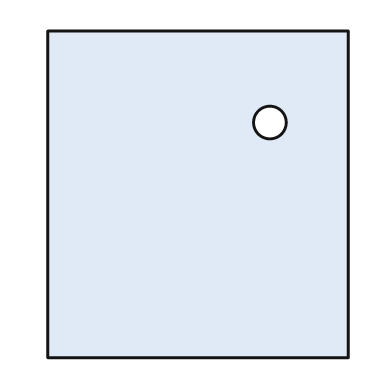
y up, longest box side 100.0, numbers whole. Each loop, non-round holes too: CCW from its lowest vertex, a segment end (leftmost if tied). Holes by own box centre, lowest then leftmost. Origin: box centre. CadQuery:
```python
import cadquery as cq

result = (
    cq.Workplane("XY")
    .moveTo(-46.0, -50.0)
    .lineTo(46.0, -50.0)
    .lineTo(46.0, 50.0)
    .lineTo(-46.0, 50.0)
    .close()
    .moveTo(22.0, 22.0)
    .circle(5.0)
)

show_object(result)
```